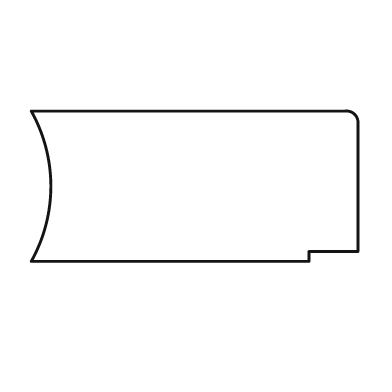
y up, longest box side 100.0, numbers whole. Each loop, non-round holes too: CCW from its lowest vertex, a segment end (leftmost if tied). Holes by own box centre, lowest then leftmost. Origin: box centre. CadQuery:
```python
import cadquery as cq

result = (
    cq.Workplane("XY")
    .moveTo(-50.0, -23.0)
    .lineTo(35.0, -23.0)
    .lineTo(35.0, -20.0)
    .lineTo(50.0, -20.0)
    .lineTo(50.0, 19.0)
    .threePointArc((49.0, 22.0), (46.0, 23.0))
    .lineTo(-50.0, 23.0)
    .threePointArc((-44.0, 0.0), (-50.0, -23.0))
    .close()
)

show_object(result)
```